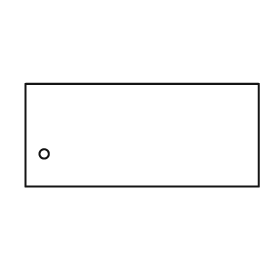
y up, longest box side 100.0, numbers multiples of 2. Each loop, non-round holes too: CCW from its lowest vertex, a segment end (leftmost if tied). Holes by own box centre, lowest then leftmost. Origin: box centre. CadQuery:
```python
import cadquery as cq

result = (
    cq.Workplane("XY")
    .moveTo(-50.0, -22.0)
    .lineTo(50.0, -22.0)
    .lineTo(50.0, 22.0)
    .lineTo(-50.0, 22.0)
    .close()
    .moveTo(-42.0, -8.0)
    .circle(2.0)
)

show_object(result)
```